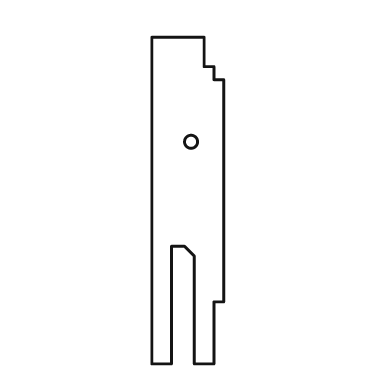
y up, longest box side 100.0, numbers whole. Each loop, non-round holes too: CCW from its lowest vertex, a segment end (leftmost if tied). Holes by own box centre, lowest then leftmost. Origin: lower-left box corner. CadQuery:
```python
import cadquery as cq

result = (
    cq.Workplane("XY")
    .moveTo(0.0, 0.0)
    .lineTo(6.0, 0.0)
    .lineTo(6.0, 36.0)
    .lineTo(10.0, 36.0)
    .lineTo(13.0, 33.0)
    .lineTo(13.0, 0.0)
    .lineTo(19.0, 0.0)
    .lineTo(19.0, 19.0)
    .lineTo(22.0, 19.0)
    .lineTo(22.0, 87.0)
    .lineTo(19.0, 87.0)
    .lineTo(19.0, 91.0)
    .lineTo(16.0, 91.0)
    .lineTo(16.0, 100.0)
    .lineTo(0.0, 100.0)
    .close()
    .moveTo(12.0, 68.0)
    .circle(2.0)
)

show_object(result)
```